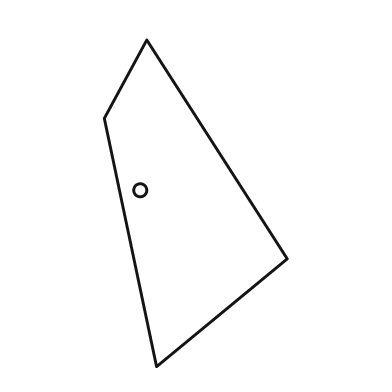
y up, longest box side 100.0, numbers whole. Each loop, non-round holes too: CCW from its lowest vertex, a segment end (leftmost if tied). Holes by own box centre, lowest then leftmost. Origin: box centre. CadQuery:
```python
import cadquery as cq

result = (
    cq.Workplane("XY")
    .moveTo(-12.0, -50.0)
    .lineTo(28.0, -17.0)
    .lineTo(-15.0, 50.0)
    .lineTo(-28.0, 26.0)
    .close()
    .moveTo(-17.0, 4.0)
    .circle(2.0)
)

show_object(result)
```